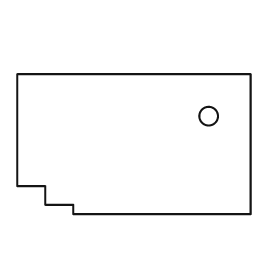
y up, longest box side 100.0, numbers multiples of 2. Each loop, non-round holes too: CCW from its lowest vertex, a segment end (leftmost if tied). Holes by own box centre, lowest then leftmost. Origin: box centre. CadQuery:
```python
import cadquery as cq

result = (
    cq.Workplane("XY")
    .moveTo(-26.0, -30.0)
    .lineTo(50.0, -30.0)
    .lineTo(50.0, 30.0)
    .lineTo(-50.0, 30.0)
    .lineTo(-50.0, -18.0)
    .lineTo(-38.0, -18.0)
    .lineTo(-38.0, -26.0)
    .lineTo(-26.0, -26.0)
    .close()
    .moveTo(32.0, 12.0)
    .circle(4.0)
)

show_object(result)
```